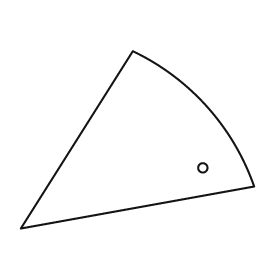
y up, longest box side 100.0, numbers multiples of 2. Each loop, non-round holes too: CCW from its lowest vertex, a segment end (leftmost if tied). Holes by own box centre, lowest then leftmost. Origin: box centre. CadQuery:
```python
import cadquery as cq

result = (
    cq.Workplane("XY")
    .moveTo(-50.0, -38.0)
    .lineTo(50.0, -20.0)
    .threePointArc((30.0, 14.0), (-2.0, 38.0))
    .close()
    .moveTo(28.0, -12.0)
    .circle(2.0)
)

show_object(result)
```